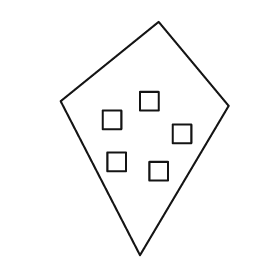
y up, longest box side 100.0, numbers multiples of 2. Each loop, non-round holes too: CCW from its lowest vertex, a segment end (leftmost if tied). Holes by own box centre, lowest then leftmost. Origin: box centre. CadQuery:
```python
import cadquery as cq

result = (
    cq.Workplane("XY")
    .moveTo(-2.0, -50.0)
    .lineTo(36.0, 14.0)
    .lineTo(6.0, 50.0)
    .lineTo(-36.0, 16.0)
    .close()
    .moveTo(2.0, -18.0)
    .lineTo(10.0, -18.0)
    .lineTo(10.0, -10.0)
    .lineTo(2.0, -10.0)
    .close()
    .moveTo(-16.0, -14.0)
    .lineTo(-8.0, -14.0)
    .lineTo(-8.0, -6.0)
    .lineTo(-16.0, -6.0)
    .close()
    .moveTo(12.0, -2.0)
    .lineTo(20.0, -2.0)
    .lineTo(20.0, 6.0)
    .lineTo(12.0, 6.0)
    .close()
    .moveTo(-18.0, 4.0)
    .lineTo(-10.0, 4.0)
    .lineTo(-10.0, 12.0)
    .lineTo(-18.0, 12.0)
    .close()
    .moveTo(-2.0, 12.0)
    .lineTo(6.0, 12.0)
    .lineTo(6.0, 20.0)
    .lineTo(-2.0, 20.0)
    .close()
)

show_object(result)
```